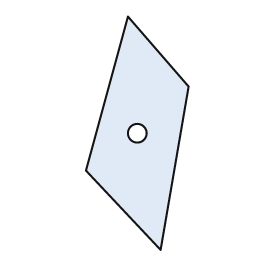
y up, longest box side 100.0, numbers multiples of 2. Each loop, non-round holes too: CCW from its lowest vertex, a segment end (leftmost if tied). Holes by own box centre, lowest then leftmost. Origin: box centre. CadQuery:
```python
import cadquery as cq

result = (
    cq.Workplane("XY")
    .moveTo(10.0, -50.0)
    .lineTo(22.0, 20.0)
    .lineTo(-4.0, 50.0)
    .lineTo(-22.0, -16.0)
    .close()
    .moveTo(0.0, 0.0)
    .circle(4.0)
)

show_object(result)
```